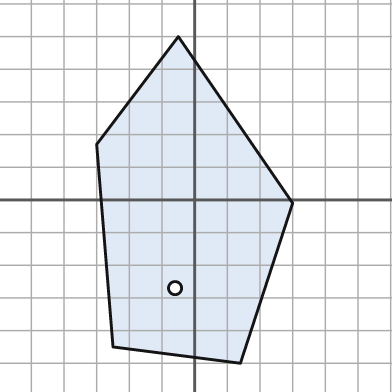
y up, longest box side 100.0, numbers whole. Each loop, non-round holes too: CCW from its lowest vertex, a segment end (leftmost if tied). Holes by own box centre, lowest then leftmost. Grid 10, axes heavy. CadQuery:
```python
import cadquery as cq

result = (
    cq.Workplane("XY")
    .moveTo(14.0, -50.0)
    .lineTo(30.0, -1.0)
    .lineTo(-5.0, 50.0)
    .lineTo(-30.0, 17.0)
    .lineTo(-25.0, -45.0)
    .close()
    .moveTo(-6.0, -27.0)
    .circle(2.0)
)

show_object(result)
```